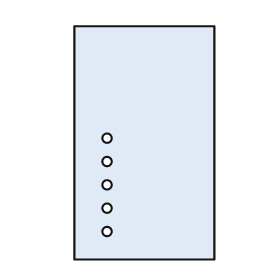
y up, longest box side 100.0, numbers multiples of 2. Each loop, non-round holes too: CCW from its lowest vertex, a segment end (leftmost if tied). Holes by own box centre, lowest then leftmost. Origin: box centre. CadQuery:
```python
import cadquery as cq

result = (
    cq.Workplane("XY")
    .moveTo(-30.0, -50.0)
    .lineTo(30.0, -50.0)
    .lineTo(30.0, 50.0)
    .lineTo(-30.0, 50.0)
    .close()
    .moveTo(-16.0, -38.0)
    .circle(2.0)
    .moveTo(-16.0, -28.0)
    .circle(2.0)
    .moveTo(-16.0, -18.0)
    .circle(2.0)
    .moveTo(-16.0, -8.0)
    .circle(2.0)
    .moveTo(-16.0, 2.0)
    .circle(2.0)
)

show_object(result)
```